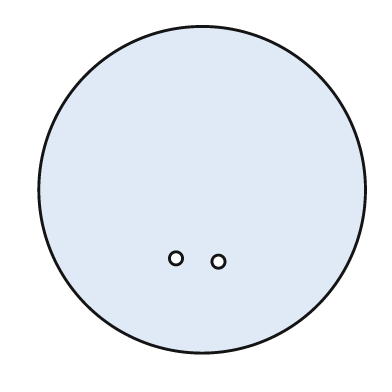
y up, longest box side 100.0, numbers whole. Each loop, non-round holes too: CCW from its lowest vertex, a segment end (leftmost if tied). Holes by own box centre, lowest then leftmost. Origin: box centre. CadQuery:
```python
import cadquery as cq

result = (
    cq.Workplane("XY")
    .moveTo(0.0, 0.0)
    .circle(50.0)
    .moveTo(5.0, -22.0)
    .circle(2.0)
    .moveTo(-8.0, -21.0)
    .circle(2.0)
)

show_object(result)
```